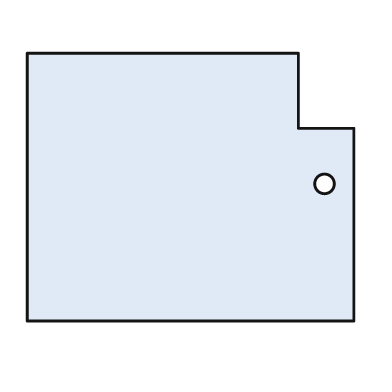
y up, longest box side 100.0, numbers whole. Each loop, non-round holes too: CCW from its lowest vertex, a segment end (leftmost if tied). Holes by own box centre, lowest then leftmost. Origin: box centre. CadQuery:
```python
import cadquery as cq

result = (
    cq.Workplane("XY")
    .moveTo(-50.0, -41.0)
    .lineTo(50.0, -41.0)
    .lineTo(50.0, 18.0)
    .lineTo(33.0, 18.0)
    .lineTo(33.0, 41.0)
    .lineTo(-50.0, 41.0)
    .close()
    .moveTo(41.0, 1.0)
    .circle(3.0)
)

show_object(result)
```